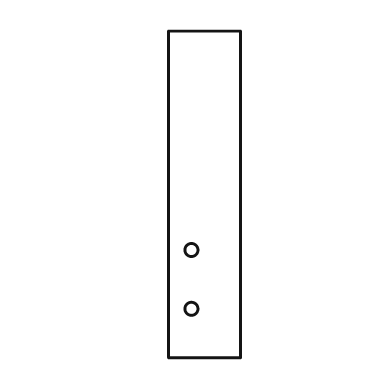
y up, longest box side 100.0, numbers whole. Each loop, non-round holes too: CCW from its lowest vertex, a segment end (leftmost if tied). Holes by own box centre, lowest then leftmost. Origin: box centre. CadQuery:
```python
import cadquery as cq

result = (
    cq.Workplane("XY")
    .moveTo(-11.0, -50.0)
    .lineTo(11.0, -50.0)
    .lineTo(11.0, 50.0)
    .lineTo(-11.0, 50.0)
    .close()
    .moveTo(-4.0, -35.0)
    .circle(2.0)
    .moveTo(-4.0, -17.0)
    .circle(2.0)
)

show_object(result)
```